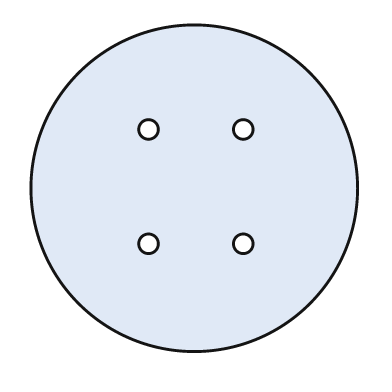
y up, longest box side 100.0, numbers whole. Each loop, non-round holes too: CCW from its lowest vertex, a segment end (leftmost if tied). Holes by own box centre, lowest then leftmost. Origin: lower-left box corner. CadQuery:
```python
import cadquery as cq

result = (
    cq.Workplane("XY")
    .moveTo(50.0, 50.0)
    .circle(50.0)
    .moveTo(36.0, 33.0)
    .circle(3.0)
    .moveTo(65.0, 33.0)
    .circle(3.0)
    .moveTo(36.0, 68.0)
    .circle(3.0)
    .moveTo(65.0, 68.0)
    .circle(3.0)
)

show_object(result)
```